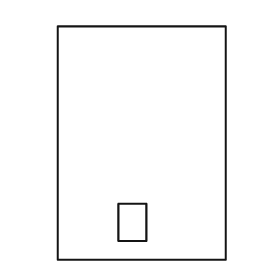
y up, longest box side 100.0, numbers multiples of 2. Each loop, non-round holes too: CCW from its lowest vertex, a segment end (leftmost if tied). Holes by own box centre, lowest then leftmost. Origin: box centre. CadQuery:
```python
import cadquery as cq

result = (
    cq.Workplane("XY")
    .moveTo(-36.0, -50.0)
    .lineTo(36.0, -50.0)
    .lineTo(36.0, 50.0)
    .lineTo(-36.0, 50.0)
    .close()
    .moveTo(-10.0, -42.0)
    .lineTo(2.0, -42.0)
    .lineTo(2.0, -26.0)
    .lineTo(-10.0, -26.0)
    .close()
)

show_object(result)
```